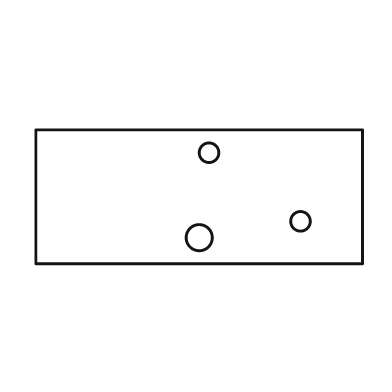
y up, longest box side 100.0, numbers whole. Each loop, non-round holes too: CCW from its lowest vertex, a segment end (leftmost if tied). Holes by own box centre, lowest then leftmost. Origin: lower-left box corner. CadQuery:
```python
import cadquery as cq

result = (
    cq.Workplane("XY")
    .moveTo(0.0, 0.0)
    .lineTo(100.0, 0.0)
    .lineTo(100.0, 41.0)
    .lineTo(0.0, 41.0)
    .close()
    .moveTo(50.0, 8.0)
    .circle(4.0)
    .moveTo(81.0, 13.0)
    .circle(3.0)
    .moveTo(53.0, 34.0)
    .circle(3.0)
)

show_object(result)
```